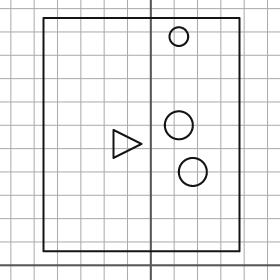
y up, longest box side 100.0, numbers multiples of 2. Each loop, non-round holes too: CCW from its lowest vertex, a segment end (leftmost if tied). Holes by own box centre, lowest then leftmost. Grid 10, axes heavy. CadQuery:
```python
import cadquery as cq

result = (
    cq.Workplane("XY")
    .moveTo(-46.0, 6.0)
    .lineTo(38.0, 6.0)
    .lineTo(38.0, 106.0)
    .lineTo(-46.0, 106.0)
    .close()
    .moveTo(18.0, 40.0)
    .circle(6.0)
    .moveTo(-16.0, 46.0)
    .lineTo(-4.0, 52.0)
    .lineTo(-16.0, 58.0)
    .close()
    .moveTo(12.0, 60.0)
    .circle(6.0)
    .moveTo(12.0, 98.0)
    .circle(4.0)
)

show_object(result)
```